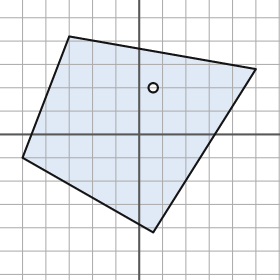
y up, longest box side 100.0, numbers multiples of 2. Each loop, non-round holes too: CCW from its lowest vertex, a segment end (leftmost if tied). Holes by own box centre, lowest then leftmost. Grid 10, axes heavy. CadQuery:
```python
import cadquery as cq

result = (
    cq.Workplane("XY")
    .moveTo(6.0, -42.0)
    .lineTo(50.0, 28.0)
    .lineTo(-30.0, 42.0)
    .lineTo(-50.0, -10.0)
    .close()
    .moveTo(6.0, 20.0)
    .circle(2.0)
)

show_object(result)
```